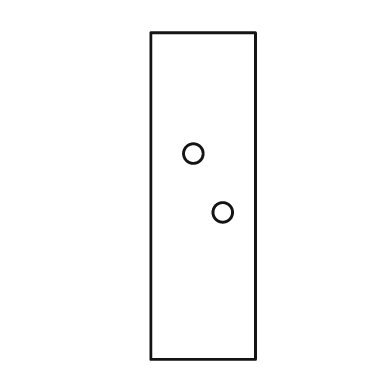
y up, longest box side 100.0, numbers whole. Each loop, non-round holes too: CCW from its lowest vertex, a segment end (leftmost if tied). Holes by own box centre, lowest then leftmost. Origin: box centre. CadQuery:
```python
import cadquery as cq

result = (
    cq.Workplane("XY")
    .moveTo(-16.0, -50.0)
    .lineTo(16.0, -50.0)
    .lineTo(16.0, 50.0)
    .lineTo(-16.0, 50.0)
    .close()
    .moveTo(6.0, -5.0)
    .circle(3.0)
    .moveTo(-3.0, 13.0)
    .circle(3.0)
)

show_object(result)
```